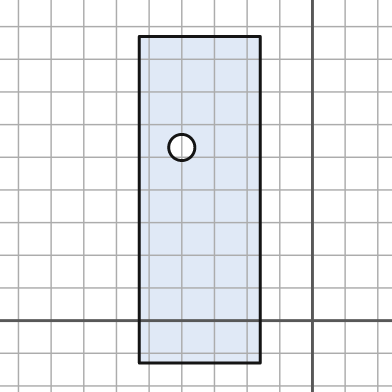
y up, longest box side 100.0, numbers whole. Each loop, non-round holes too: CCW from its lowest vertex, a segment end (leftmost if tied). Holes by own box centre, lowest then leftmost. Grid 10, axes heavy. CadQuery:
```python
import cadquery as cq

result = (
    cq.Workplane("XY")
    .moveTo(-53.0, -13.0)
    .lineTo(-16.0, -13.0)
    .lineTo(-16.0, 87.0)
    .lineTo(-53.0, 87.0)
    .close()
    .moveTo(-40.0, 53.0)
    .circle(4.0)
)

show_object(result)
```